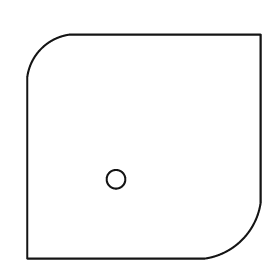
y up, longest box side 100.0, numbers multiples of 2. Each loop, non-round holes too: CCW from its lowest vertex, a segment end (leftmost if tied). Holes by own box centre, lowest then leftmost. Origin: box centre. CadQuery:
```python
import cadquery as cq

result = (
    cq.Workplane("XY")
    .moveTo(-50.0, -48.0)
    .lineTo(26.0, -48.0)
    .threePointArc((42.0, -40.0), (50.0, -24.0))
    .lineTo(50.0, 48.0)
    .lineTo(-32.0, 48.0)
    .threePointArc((-44.0, 42.0), (-50.0, 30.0))
    .close()
    .moveTo(-12.0, -14.0)
    .circle(4.0)
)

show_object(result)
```